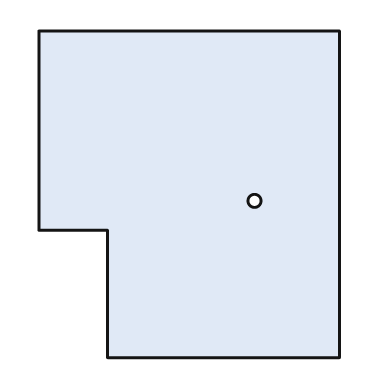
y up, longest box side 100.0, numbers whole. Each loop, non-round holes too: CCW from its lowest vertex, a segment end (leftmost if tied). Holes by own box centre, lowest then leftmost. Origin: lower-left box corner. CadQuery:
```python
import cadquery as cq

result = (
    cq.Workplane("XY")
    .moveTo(21.0, 0.0)
    .lineTo(92.0, 0.0)
    .lineTo(92.0, 100.0)
    .lineTo(0.0, 100.0)
    .lineTo(0.0, 39.0)
    .lineTo(21.0, 39.0)
    .close()
    .moveTo(66.0, 48.0)
    .circle(2.0)
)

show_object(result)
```